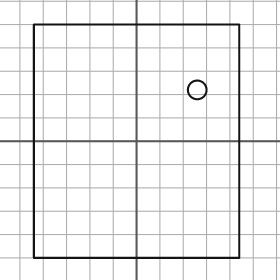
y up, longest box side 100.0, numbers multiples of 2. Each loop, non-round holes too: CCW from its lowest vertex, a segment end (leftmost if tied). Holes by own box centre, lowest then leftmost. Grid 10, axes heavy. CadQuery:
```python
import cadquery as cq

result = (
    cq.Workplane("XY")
    .moveTo(-44.0, -50.0)
    .lineTo(44.0, -50.0)
    .lineTo(44.0, 50.0)
    .lineTo(-44.0, 50.0)
    .close()
    .moveTo(26.0, 22.0)
    .circle(4.0)
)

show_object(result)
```